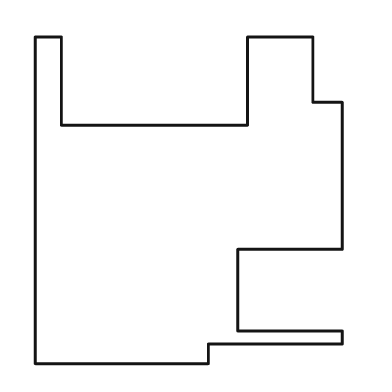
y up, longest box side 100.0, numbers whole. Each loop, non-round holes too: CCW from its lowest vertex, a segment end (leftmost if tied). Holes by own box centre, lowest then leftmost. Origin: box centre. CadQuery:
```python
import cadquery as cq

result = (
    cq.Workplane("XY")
    .moveTo(-47.0, -50.0)
    .lineTo(6.0, -50.0)
    .lineTo(6.0, -44.0)
    .lineTo(47.0, -44.0)
    .lineTo(47.0, -40.0)
    .lineTo(15.0, -40.0)
    .lineTo(15.0, -15.0)
    .lineTo(47.0, -15.0)
    .lineTo(47.0, 30.0)
    .lineTo(38.0, 30.0)
    .lineTo(38.0, 50.0)
    .lineTo(18.0, 50.0)
    .lineTo(18.0, 23.0)
    .lineTo(-39.0, 23.0)
    .lineTo(-39.0, 50.0)
    .lineTo(-47.0, 50.0)
    .close()
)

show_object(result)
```